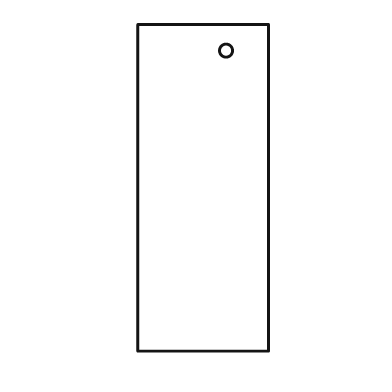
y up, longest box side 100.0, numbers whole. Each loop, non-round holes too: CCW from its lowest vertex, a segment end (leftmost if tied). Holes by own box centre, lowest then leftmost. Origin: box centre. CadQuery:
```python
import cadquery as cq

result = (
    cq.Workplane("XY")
    .moveTo(-20.0, -50.0)
    .lineTo(20.0, -50.0)
    .lineTo(20.0, 50.0)
    .lineTo(-20.0, 50.0)
    .close()
    .moveTo(7.0, 42.0)
    .circle(2.0)
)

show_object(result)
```